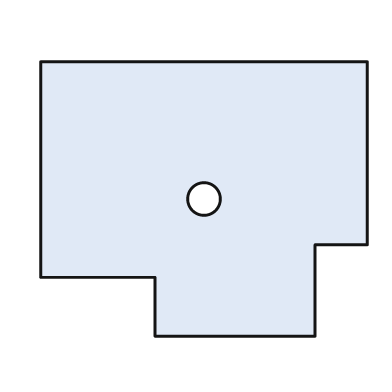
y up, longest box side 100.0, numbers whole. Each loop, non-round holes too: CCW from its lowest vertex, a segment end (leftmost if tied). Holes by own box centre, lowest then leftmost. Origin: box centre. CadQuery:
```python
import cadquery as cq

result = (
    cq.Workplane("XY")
    .moveTo(-15.0, -42.0)
    .lineTo(34.0, -42.0)
    .lineTo(34.0, -14.0)
    .lineTo(50.0, -14.0)
    .lineTo(50.0, 42.0)
    .lineTo(-50.0, 42.0)
    .lineTo(-50.0, -24.0)
    .lineTo(-15.0, -24.0)
    .close()
    .moveTo(0.0, 0.0)
    .circle(5.0)
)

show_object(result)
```